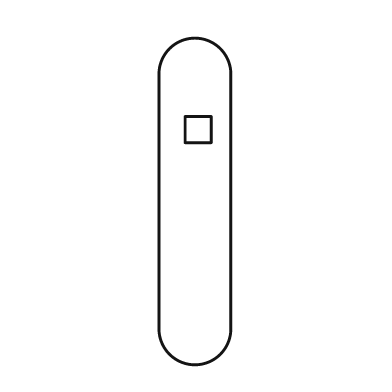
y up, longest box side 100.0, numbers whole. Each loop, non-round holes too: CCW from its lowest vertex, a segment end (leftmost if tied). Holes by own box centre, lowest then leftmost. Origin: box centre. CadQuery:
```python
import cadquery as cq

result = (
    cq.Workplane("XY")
    .moveTo(-11.0, -39.0)
    .threePointArc((0.0, -50.0), (11.0, -39.0))
    .lineTo(11.0, 39.0)
    .threePointArc((0.0, 50.0), (-11.0, 39.0))
    .close()
    .moveTo(-3.0, 18.0)
    .lineTo(5.0, 18.0)
    .lineTo(5.0, 26.0)
    .lineTo(-3.0, 26.0)
    .close()
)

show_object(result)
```